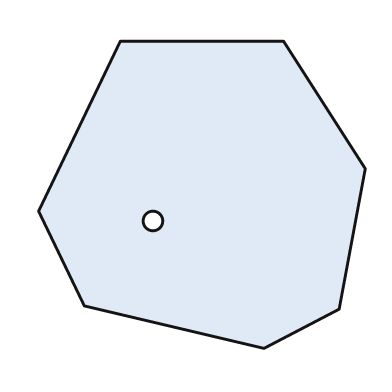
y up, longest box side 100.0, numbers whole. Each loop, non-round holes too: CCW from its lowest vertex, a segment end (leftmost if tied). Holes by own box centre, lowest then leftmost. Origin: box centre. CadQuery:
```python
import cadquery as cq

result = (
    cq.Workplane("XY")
    .moveTo(19.0, -47.0)
    .lineTo(42.0, -35.0)
    .lineTo(50.0, 8.0)
    .lineTo(25.0, 47.0)
    .lineTo(-25.0, 47.0)
    .lineTo(-50.0, -5.0)
    .lineTo(-36.0, -34.0)
    .close()
    .moveTo(-15.0, -8.0)
    .circle(3.0)
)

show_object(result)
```